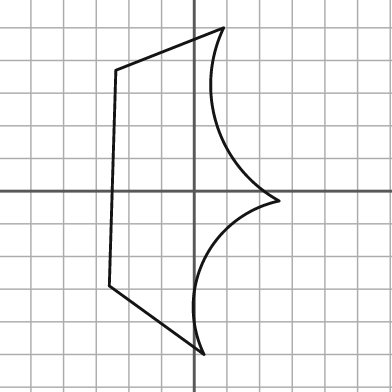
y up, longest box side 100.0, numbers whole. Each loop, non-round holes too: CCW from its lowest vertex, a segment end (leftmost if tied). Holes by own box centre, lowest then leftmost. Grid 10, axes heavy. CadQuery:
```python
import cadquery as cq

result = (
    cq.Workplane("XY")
    .moveTo(3.0, -50.0)
    .threePointArc((3.0, -21.0), (26.0, -3.0))
    .threePointArc((7.0, 20.0), (9.0, 50.0))
    .lineTo(-24.0, 37.0)
    .lineTo(-26.0, -29.0)
    .close()
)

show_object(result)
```